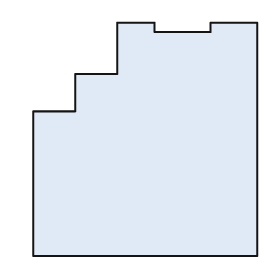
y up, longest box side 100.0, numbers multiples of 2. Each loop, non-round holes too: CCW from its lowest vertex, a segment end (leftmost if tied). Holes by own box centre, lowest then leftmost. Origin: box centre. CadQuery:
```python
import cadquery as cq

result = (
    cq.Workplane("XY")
    .moveTo(-48.0, -50.0)
    .lineTo(48.0, -50.0)
    .lineTo(48.0, 50.0)
    .lineTo(28.0, 50.0)
    .lineTo(28.0, 46.0)
    .lineTo(4.0, 46.0)
    .lineTo(4.0, 50.0)
    .lineTo(-12.0, 50.0)
    .lineTo(-12.0, 28.0)
    .lineTo(-30.0, 28.0)
    .lineTo(-30.0, 12.0)
    .lineTo(-48.0, 12.0)
    .close()
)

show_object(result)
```